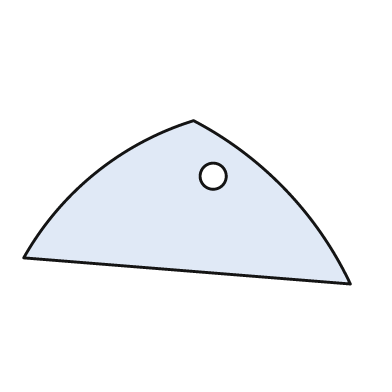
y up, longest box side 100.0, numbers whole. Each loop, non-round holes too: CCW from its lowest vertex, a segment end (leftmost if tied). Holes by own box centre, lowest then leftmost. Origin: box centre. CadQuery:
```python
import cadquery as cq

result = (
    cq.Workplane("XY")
    .moveTo(50.0, -25.0)
    .threePointArc((30.0, 4.0), (2.0, 25.0))
    .threePointArc((-28.0, 9.0), (-50.0, -17.0))
    .close()
    .moveTo(8.0, 8.0)
    .circle(4.0)
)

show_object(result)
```